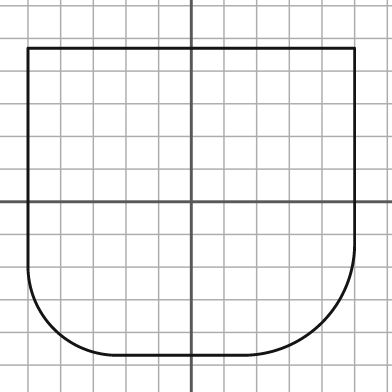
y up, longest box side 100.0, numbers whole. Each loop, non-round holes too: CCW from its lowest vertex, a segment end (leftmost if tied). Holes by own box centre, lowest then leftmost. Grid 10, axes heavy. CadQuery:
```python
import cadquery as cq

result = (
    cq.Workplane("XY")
    .moveTo(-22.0, -47.0)
    .lineTo(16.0, -47.0)
    .threePointArc((40.0, -37.0), (50.0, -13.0))
    .lineTo(50.0, 47.0)
    .lineTo(-50.0, 47.0)
    .lineTo(-50.0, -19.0)
    .threePointArc((-42.0, -39.0), (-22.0, -47.0))
    .close()
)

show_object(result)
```